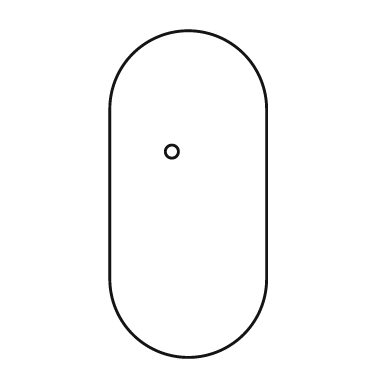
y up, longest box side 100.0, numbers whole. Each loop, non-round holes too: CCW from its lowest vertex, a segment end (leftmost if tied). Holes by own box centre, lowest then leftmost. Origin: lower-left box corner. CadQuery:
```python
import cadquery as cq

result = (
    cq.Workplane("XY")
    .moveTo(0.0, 24.0)
    .threePointArc((24.0, 0.0), (48.0, 24.0))
    .lineTo(48.0, 76.0)
    .threePointArc((24.0, 100.0), (0.0, 76.0))
    .close()
    .moveTo(19.0, 63.0)
    .circle(2.0)
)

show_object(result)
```